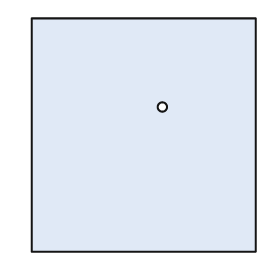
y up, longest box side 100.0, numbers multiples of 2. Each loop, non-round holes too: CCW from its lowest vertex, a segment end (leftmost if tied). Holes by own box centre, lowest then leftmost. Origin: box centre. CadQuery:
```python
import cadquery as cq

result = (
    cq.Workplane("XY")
    .moveTo(-48.0, -50.0)
    .lineTo(48.0, -50.0)
    .lineTo(48.0, 50.0)
    .lineTo(-48.0, 50.0)
    .close()
    .moveTo(8.0, 12.0)
    .circle(2.0)
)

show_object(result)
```